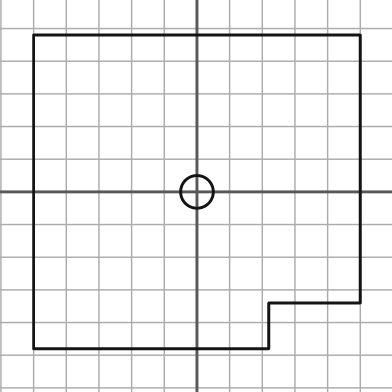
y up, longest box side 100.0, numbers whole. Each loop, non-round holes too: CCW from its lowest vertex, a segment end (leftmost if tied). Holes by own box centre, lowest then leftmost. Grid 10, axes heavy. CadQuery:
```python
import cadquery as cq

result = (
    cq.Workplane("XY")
    .moveTo(-50.0, -48.0)
    .lineTo(22.0, -48.0)
    .lineTo(22.0, -34.0)
    .lineTo(50.0, -34.0)
    .lineTo(50.0, 48.0)
    .lineTo(-50.0, 48.0)
    .close()
    .moveTo(0.0, 0.0)
    .circle(5.0)
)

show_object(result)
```